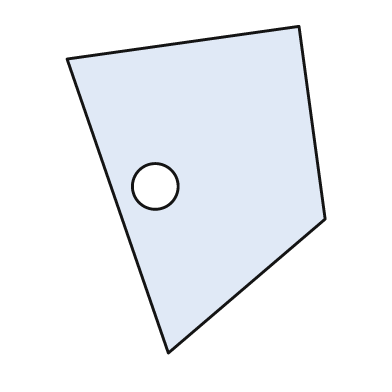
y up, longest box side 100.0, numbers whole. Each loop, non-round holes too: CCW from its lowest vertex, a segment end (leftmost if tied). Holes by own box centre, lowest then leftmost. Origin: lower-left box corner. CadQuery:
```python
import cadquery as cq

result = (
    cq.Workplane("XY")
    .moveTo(31.0, 0.0)
    .lineTo(79.0, 41.0)
    .lineTo(71.0, 100.0)
    .lineTo(0.0, 90.0)
    .close()
    .moveTo(27.0, 51.0)
    .circle(7.0)
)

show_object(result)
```